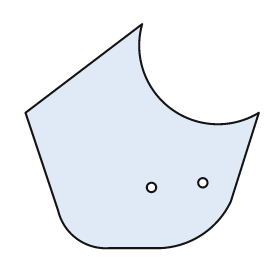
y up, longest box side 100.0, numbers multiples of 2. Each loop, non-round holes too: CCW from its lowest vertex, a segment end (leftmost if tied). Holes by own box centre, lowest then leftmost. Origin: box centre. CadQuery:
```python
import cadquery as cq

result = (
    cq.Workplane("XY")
    .moveTo(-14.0, -48.0)
    .lineTo(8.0, -48.0)
    .threePointArc((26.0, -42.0), (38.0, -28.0))
    .lineTo(50.0, 10.0)
    .threePointArc((12.0, 12.0), (0.0, 48.0))
    .lineTo(-50.0, 10.0)
    .lineTo(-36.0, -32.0)
    .threePointArc((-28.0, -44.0), (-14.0, -48.0))
    .close()
    .moveTo(4.0, -22.0)
    .circle(2.0)
    .moveTo(26.0, -20.0)
    .circle(2.0)
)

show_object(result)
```